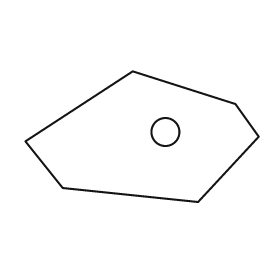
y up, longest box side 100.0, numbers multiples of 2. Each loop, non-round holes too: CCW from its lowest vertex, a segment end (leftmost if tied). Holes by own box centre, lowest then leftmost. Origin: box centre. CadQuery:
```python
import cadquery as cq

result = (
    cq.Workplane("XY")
    .moveTo(24.0, -28.0)
    .lineTo(50.0, 0.0)
    .lineTo(40.0, 14.0)
    .lineTo(-4.0, 28.0)
    .lineTo(-50.0, -2.0)
    .lineTo(-34.0, -22.0)
    .close()
    .moveTo(10.0, 2.0)
    .circle(6.0)
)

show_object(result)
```